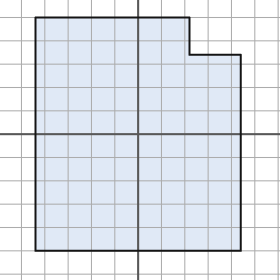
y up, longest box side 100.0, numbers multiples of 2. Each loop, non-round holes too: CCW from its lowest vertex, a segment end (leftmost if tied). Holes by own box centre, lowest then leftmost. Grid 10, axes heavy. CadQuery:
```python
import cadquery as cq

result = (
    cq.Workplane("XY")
    .moveTo(-44.0, -50.0)
    .lineTo(44.0, -50.0)
    .lineTo(44.0, 34.0)
    .lineTo(22.0, 34.0)
    .lineTo(22.0, 50.0)
    .lineTo(-44.0, 50.0)
    .close()
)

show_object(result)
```